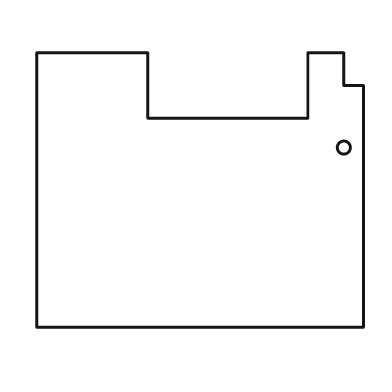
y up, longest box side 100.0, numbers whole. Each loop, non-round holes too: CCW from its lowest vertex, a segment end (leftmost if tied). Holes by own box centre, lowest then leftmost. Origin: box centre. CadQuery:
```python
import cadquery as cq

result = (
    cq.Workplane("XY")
    .moveTo(-50.0, -42.0)
    .lineTo(50.0, -42.0)
    .lineTo(50.0, 32.0)
    .lineTo(44.0, 32.0)
    .lineTo(44.0, 42.0)
    .lineTo(33.0, 42.0)
    .lineTo(33.0, 22.0)
    .lineTo(-16.0, 22.0)
    .lineTo(-16.0, 42.0)
    .lineTo(-50.0, 42.0)
    .close()
    .moveTo(44.0, 13.0)
    .circle(2.0)
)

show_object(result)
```